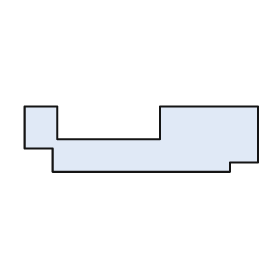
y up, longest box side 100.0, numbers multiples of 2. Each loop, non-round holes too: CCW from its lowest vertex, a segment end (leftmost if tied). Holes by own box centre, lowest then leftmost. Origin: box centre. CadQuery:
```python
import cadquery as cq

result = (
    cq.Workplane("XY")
    .moveTo(-38.0, -14.0)
    .lineTo(38.0, -14.0)
    .lineTo(38.0, -10.0)
    .lineTo(50.0, -10.0)
    .lineTo(50.0, 14.0)
    .lineTo(8.0, 14.0)
    .lineTo(8.0, 0.0)
    .lineTo(-36.0, 0.0)
    .lineTo(-36.0, 14.0)
    .lineTo(-50.0, 14.0)
    .lineTo(-50.0, -4.0)
    .lineTo(-38.0, -4.0)
    .close()
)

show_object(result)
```